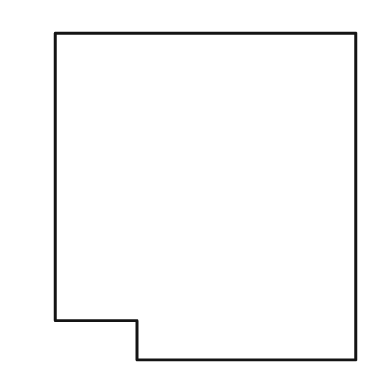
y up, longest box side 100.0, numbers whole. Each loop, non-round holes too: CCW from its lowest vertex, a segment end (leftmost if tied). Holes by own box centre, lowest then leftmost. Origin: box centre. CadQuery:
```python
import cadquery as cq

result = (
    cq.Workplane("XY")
    .moveTo(-21.0, -50.0)
    .lineTo(46.0, -50.0)
    .lineTo(46.0, 50.0)
    .lineTo(-46.0, 50.0)
    .lineTo(-46.0, -38.0)
    .lineTo(-21.0, -38.0)
    .close()
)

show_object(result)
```